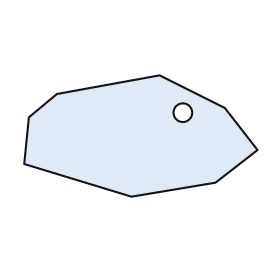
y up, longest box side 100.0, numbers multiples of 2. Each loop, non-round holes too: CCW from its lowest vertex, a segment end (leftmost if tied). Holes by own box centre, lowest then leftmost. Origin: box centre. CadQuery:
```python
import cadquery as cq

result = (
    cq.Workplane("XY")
    .moveTo(-4.0, -26.0)
    .lineTo(32.0, -20.0)
    .lineTo(50.0, -6.0)
    .lineTo(36.0, 12.0)
    .lineTo(8.0, 26.0)
    .lineTo(-36.0, 18.0)
    .lineTo(-48.0, 8.0)
    .lineTo(-50.0, -12.0)
    .close()
    .moveTo(18.0, 10.0)
    .circle(4.0)
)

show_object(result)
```